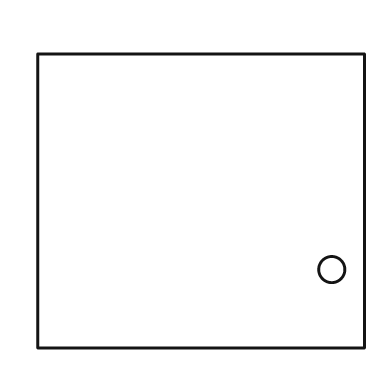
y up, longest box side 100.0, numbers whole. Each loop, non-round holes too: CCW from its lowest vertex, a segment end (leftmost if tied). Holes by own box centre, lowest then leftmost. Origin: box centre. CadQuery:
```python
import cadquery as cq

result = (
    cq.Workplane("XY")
    .moveTo(-50.0, -45.0)
    .lineTo(50.0, -45.0)
    .lineTo(50.0, 45.0)
    .lineTo(-50.0, 45.0)
    .close()
    .moveTo(40.0, -21.0)
    .circle(4.0)
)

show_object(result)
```